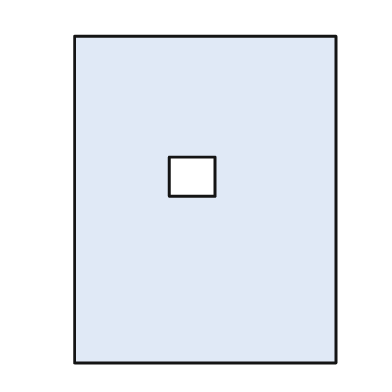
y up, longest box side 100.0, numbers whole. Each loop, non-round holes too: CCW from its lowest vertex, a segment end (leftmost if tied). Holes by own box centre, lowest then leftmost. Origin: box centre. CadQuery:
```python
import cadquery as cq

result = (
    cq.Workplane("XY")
    .moveTo(-40.0, -50.0)
    .lineTo(40.0, -50.0)
    .lineTo(40.0, 50.0)
    .lineTo(-40.0, 50.0)
    .close()
    .moveTo(-11.0, 1.0)
    .lineTo(3.0, 1.0)
    .lineTo(3.0, 13.0)
    .lineTo(-11.0, 13.0)
    .close()
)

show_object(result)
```